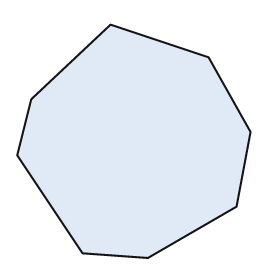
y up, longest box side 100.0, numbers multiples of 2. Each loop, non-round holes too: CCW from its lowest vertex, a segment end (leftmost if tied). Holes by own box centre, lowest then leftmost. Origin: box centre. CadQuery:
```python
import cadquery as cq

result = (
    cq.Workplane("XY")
    .moveTo(6.0, -50.0)
    .lineTo(44.0, -28.0)
    .lineTo(50.0, 4.0)
    .lineTo(32.0, 36.0)
    .lineTo(-10.0, 50.0)
    .lineTo(-44.0, 18.0)
    .lineTo(-50.0, -6.0)
    .lineTo(-22.0, -48.0)
    .close()
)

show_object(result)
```